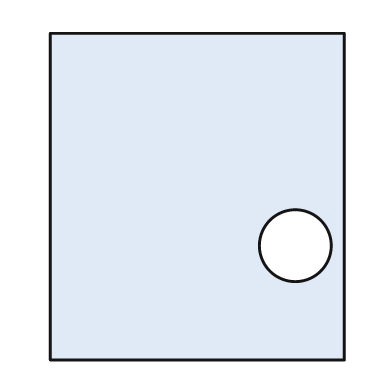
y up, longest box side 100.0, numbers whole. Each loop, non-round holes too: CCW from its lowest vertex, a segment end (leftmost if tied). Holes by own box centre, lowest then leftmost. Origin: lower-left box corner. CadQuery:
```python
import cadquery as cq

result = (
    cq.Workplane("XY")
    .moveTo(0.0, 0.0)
    .lineTo(90.0, 0.0)
    .lineTo(90.0, 100.0)
    .lineTo(0.0, 100.0)
    .close()
    .moveTo(75.0, 35.0)
    .circle(11.0)
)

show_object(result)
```